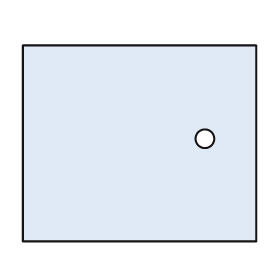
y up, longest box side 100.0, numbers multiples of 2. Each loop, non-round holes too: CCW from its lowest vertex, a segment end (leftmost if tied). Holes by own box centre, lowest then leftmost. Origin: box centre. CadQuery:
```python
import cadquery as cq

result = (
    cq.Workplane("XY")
    .moveTo(-50.0, -42.0)
    .lineTo(50.0, -42.0)
    .lineTo(50.0, 42.0)
    .lineTo(-50.0, 42.0)
    .close()
    .moveTo(28.0, 2.0)
    .circle(4.0)
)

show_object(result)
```